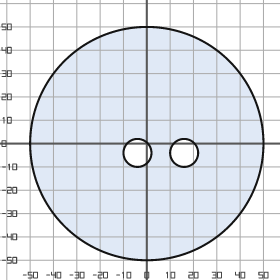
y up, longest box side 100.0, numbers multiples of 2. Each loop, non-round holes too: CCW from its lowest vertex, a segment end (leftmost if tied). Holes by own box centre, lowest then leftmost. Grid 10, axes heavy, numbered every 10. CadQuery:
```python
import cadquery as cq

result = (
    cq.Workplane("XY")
    .moveTo(0.0, 0.0)
    .circle(50.0)
    .moveTo(-4.0, -4.0)
    .circle(6.0)
    .moveTo(16.0, -4.0)
    .circle(6.0)
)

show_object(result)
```